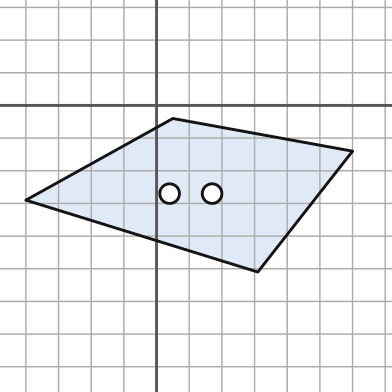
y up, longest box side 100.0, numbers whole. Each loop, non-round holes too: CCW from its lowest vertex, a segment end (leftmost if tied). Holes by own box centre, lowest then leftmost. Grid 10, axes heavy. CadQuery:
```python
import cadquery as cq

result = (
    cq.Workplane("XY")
    .moveTo(31.0, -51.0)
    .lineTo(60.0, -14.0)
    .lineTo(5.0, -4.0)
    .lineTo(-40.0, -29.0)
    .close()
    .moveTo(4.0, -27.0)
    .circle(3.0)
    .moveTo(17.0, -27.0)
    .circle(3.0)
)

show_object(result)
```